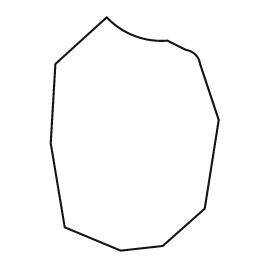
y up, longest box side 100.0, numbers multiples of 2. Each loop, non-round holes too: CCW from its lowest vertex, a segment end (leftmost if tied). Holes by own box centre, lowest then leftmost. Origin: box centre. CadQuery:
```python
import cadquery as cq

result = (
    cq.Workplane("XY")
    .moveTo(-6.0, -50.0)
    .lineTo(12.0, -48.0)
    .lineTo(30.0, -32.0)
    .lineTo(36.0, 6.0)
    .lineTo(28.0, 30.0)
    .threePointArc((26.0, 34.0), (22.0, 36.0))
    .lineTo(14.0, 40.0)
    .threePointArc((0.0, 42.0), (-12.0, 50.0))
    .lineTo(-34.0, 30.0)
    .lineTo(-36.0, -4.0)
    .lineTo(-30.0, -40.0)
    .close()
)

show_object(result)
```